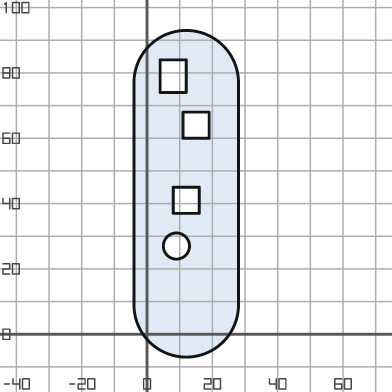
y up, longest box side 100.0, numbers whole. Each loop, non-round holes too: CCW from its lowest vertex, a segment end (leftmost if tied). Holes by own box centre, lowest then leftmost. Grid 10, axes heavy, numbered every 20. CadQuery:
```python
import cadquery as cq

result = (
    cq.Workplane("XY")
    .moveTo(-4.0, 9.0)
    .threePointArc((12.0, -7.0), (28.0, 9.0))
    .lineTo(28.0, 77.0)
    .threePointArc((12.0, 93.0), (-4.0, 77.0))
    .close()
    .moveTo(9.0, 27.0)
    .circle(4.0)
    .moveTo(8.0, 37.0)
    .lineTo(16.0, 37.0)
    .lineTo(16.0, 45.0)
    .lineTo(8.0, 45.0)
    .close()
    .moveTo(11.0, 60.0)
    .lineTo(19.0, 60.0)
    .lineTo(19.0, 68.0)
    .lineTo(11.0, 68.0)
    .close()
    .moveTo(4.0, 74.0)
    .lineTo(12.0, 74.0)
    .lineTo(12.0, 84.0)
    .lineTo(4.0, 84.0)
    .close()
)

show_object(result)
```